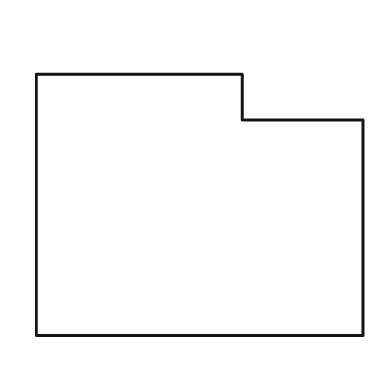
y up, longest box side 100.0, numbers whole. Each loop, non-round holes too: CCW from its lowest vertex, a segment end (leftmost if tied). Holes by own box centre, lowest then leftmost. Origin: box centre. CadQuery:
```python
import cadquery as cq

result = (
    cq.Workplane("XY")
    .moveTo(-50.0, -40.0)
    .lineTo(50.0, -40.0)
    .lineTo(50.0, 26.0)
    .lineTo(13.0, 26.0)
    .lineTo(13.0, 40.0)
    .lineTo(-50.0, 40.0)
    .close()
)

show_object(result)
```